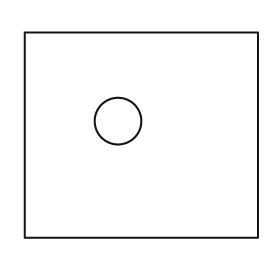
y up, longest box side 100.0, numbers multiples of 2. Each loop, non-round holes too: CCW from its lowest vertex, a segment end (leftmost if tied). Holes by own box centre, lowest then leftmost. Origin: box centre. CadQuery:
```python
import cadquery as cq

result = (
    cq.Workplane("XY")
    .moveTo(-50.0, -44.0)
    .lineTo(50.0, -44.0)
    .lineTo(50.0, 44.0)
    .lineTo(-50.0, 44.0)
    .close()
    .moveTo(-10.0, 6.0)
    .circle(10.0)
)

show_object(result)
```